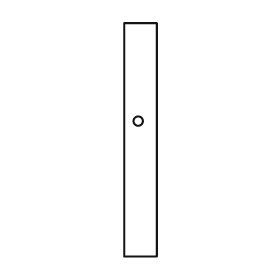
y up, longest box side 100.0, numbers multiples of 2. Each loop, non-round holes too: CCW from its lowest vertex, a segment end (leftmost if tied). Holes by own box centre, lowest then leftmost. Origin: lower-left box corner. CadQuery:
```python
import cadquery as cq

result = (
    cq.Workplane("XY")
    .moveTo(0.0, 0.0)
    .lineTo(14.0, 0.0)
    .lineTo(14.0, 100.0)
    .lineTo(0.0, 100.0)
    .close()
    .moveTo(6.0, 58.0)
    .circle(2.0)
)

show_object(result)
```